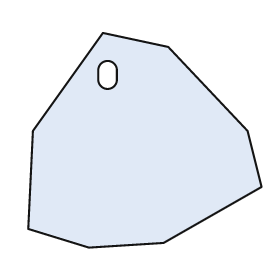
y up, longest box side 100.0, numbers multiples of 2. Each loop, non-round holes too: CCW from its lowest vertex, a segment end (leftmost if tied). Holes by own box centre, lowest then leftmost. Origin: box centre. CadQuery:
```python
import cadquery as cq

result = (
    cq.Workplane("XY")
    .moveTo(-24.0, -46.0)
    .lineTo(8.0, -44.0)
    .lineTo(50.0, -20.0)
    .lineTo(44.0, 4.0)
    .lineTo(10.0, 40.0)
    .lineTo(-18.0, 46.0)
    .lineTo(-48.0, 4.0)
    .lineTo(-50.0, -38.0)
    .close()
    .moveTo(-20.0, 26.0)
    .threePointArc((-16.0, 22.0), (-12.0, 26.0))
    .lineTo(-12.0, 30.0)
    .threePointArc((-16.0, 34.0), (-20.0, 30.0))
    .close()
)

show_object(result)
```